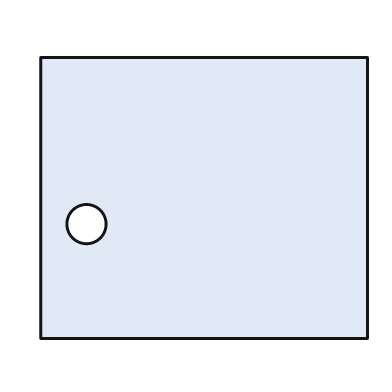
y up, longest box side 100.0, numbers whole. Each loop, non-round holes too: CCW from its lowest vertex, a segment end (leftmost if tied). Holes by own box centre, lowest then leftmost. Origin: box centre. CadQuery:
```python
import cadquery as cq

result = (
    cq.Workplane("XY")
    .moveTo(-50.0, -43.0)
    .lineTo(50.0, -43.0)
    .lineTo(50.0, 43.0)
    .lineTo(-50.0, 43.0)
    .close()
    .moveTo(-36.0, -8.0)
    .circle(6.0)
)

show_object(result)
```